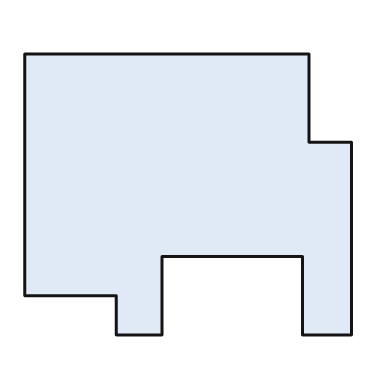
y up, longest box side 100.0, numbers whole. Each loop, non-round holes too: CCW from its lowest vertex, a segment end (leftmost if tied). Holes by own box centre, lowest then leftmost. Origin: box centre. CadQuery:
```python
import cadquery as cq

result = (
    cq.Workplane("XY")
    .moveTo(-22.0, -43.0)
    .lineTo(-8.0, -43.0)
    .lineTo(-8.0, -19.0)
    .lineTo(35.0, -19.0)
    .lineTo(35.0, -43.0)
    .lineTo(50.0, -43.0)
    .lineTo(50.0, 16.0)
    .lineTo(37.0, 16.0)
    .lineTo(37.0, 43.0)
    .lineTo(-50.0, 43.0)
    .lineTo(-50.0, -31.0)
    .lineTo(-22.0, -31.0)
    .close()
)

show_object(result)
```